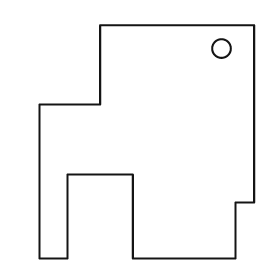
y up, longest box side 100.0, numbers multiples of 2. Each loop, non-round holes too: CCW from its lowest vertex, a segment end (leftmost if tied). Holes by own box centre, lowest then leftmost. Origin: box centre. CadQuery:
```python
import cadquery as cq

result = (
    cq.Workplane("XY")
    .moveTo(-46.0, -50.0)
    .lineTo(-34.0, -50.0)
    .lineTo(-34.0, -14.0)
    .lineTo(-6.0, -14.0)
    .lineTo(-6.0, -50.0)
    .lineTo(38.0, -50.0)
    .lineTo(38.0, -26.0)
    .lineTo(46.0, -26.0)
    .lineTo(46.0, 50.0)
    .lineTo(-20.0, 50.0)
    .lineTo(-20.0, 16.0)
    .lineTo(-46.0, 16.0)
    .close()
    .moveTo(32.0, 40.0)
    .circle(4.0)
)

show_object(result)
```